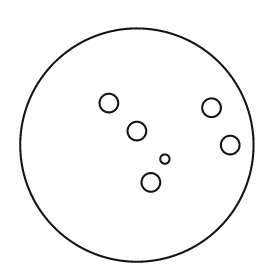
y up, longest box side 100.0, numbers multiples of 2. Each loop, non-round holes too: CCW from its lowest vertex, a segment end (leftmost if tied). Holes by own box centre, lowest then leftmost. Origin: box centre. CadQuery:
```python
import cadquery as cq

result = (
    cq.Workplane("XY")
    .moveTo(0.0, 0.0)
    .circle(50.0)
    .moveTo(6.0, -16.0)
    .circle(4.0)
    .moveTo(12.0, -6.0)
    .circle(2.0)
    .moveTo(40.0, 0.0)
    .circle(4.0)
    .moveTo(0.0, 6.0)
    .circle(4.0)
    .moveTo(32.0, 16.0)
    .circle(4.0)
    .moveTo(-12.0, 18.0)
    .circle(4.0)
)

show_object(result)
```